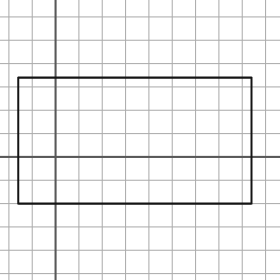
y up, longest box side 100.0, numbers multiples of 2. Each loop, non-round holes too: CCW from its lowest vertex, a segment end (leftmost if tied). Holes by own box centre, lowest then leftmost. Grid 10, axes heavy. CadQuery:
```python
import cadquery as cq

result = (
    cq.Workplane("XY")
    .moveTo(-16.0, -20.0)
    .lineTo(84.0, -20.0)
    .lineTo(84.0, 34.0)
    .lineTo(-16.0, 34.0)
    .close()
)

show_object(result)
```